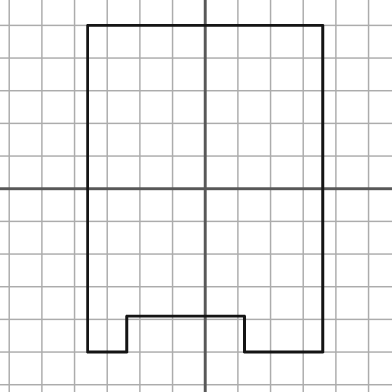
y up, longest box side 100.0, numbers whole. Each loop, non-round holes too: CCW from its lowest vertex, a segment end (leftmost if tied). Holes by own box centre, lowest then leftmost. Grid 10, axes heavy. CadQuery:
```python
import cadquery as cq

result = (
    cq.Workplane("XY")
    .moveTo(-36.0, -50.0)
    .lineTo(-24.0, -50.0)
    .lineTo(-24.0, -39.0)
    .lineTo(12.0, -39.0)
    .lineTo(12.0, -50.0)
    .lineTo(36.0, -50.0)
    .lineTo(36.0, 50.0)
    .lineTo(-36.0, 50.0)
    .close()
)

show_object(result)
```